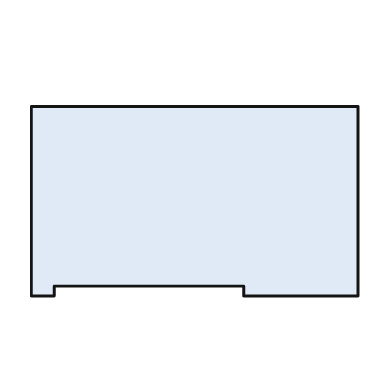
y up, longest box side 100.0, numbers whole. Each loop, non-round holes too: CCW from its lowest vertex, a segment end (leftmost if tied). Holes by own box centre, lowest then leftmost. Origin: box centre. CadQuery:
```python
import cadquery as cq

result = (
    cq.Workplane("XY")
    .moveTo(-50.0, -29.0)
    .lineTo(-43.0, -29.0)
    .lineTo(-43.0, -26.0)
    .lineTo(15.0, -26.0)
    .lineTo(15.0, -29.0)
    .lineTo(50.0, -29.0)
    .lineTo(50.0, 29.0)
    .lineTo(-50.0, 29.0)
    .close()
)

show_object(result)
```